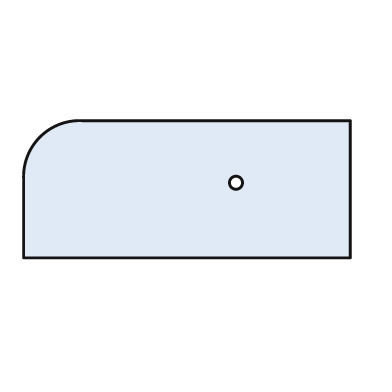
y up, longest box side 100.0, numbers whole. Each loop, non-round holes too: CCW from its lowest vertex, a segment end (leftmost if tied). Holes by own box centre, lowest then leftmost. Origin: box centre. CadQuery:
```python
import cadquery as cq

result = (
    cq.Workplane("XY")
    .moveTo(-50.0, -21.0)
    .lineTo(50.0, -21.0)
    .lineTo(50.0, 21.0)
    .lineTo(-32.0, 21.0)
    .threePointArc((-45.0, 16.0), (-50.0, 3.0))
    .close()
    .moveTo(15.0, 2.0)
    .circle(2.0)
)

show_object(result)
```